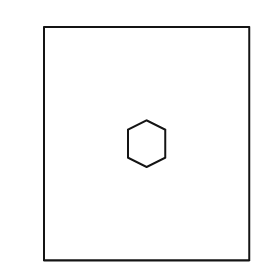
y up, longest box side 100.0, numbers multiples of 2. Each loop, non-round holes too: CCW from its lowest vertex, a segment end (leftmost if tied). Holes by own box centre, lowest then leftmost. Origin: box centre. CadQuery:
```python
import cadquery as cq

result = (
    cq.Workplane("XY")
    .moveTo(-44.0, -50.0)
    .lineTo(44.0, -50.0)
    .lineTo(44.0, 50.0)
    .lineTo(-44.0, 50.0)
    .close()
    .moveTo(0.0, -10.0)
    .lineTo(8.0, -6.0)
    .lineTo(8.0, 6.0)
    .lineTo(0.0, 10.0)
    .lineTo(-8.0, 6.0)
    .lineTo(-8.0, -6.0)
    .close()
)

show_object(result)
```